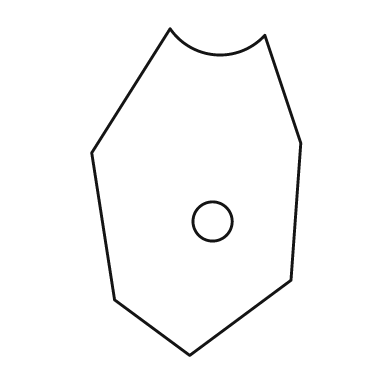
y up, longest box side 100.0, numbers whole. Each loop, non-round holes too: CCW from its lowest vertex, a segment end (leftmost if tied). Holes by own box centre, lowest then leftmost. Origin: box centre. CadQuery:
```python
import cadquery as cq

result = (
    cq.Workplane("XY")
    .moveTo(-2.0, -50.0)
    .lineTo(29.0, -27.0)
    .lineTo(32.0, 15.0)
    .lineTo(21.0, 48.0)
    .threePointArc((6.0, 42.0), (-8.0, 50.0))
    .lineTo(-32.0, 12.0)
    .lineTo(-25.0, -33.0)
    .close()
    .moveTo(5.0, -9.0)
    .circle(6.0)
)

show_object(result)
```